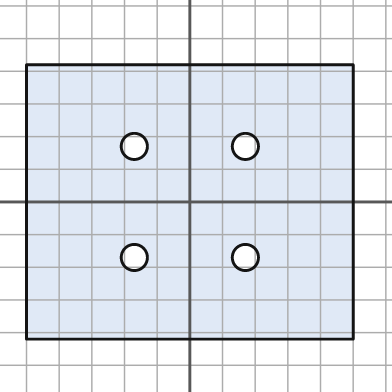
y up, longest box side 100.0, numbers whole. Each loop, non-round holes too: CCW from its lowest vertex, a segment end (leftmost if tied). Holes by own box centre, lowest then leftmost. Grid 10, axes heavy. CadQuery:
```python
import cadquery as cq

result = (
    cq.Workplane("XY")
    .moveTo(-50.0, -42.0)
    .lineTo(50.0, -42.0)
    .lineTo(50.0, 42.0)
    .lineTo(-50.0, 42.0)
    .close()
    .moveTo(-17.0, -17.0)
    .circle(4.0)
    .moveTo(17.0, -17.0)
    .circle(4.0)
    .moveTo(-17.0, 17.0)
    .circle(4.0)
    .moveTo(17.0, 17.0)
    .circle(4.0)
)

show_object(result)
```